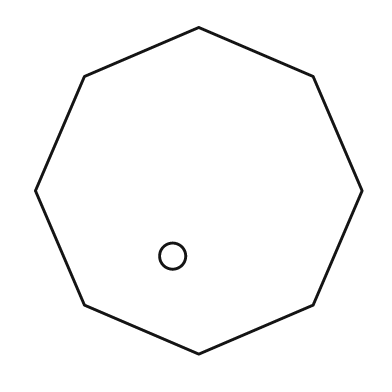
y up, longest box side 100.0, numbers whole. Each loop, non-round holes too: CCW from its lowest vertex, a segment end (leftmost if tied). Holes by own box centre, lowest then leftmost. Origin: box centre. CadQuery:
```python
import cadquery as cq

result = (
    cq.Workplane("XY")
    .moveTo(0.0, -50.0)
    .lineTo(35.0, -35.0)
    .lineTo(50.0, 0.0)
    .lineTo(35.0, 35.0)
    .lineTo(0.0, 50.0)
    .lineTo(-35.0, 35.0)
    .lineTo(-50.0, 0.0)
    .lineTo(-35.0, -35.0)
    .close()
    .moveTo(-8.0, -20.0)
    .circle(4.0)
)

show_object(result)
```